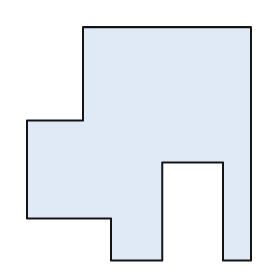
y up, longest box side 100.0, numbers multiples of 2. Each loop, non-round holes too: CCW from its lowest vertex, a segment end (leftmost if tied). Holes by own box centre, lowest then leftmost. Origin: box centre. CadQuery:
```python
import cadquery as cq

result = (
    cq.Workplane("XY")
    .moveTo(-12.0, -50.0)
    .lineTo(10.0, -50.0)
    .lineTo(10.0, -8.0)
    .lineTo(36.0, -8.0)
    .lineTo(36.0, -50.0)
    .lineTo(48.0, -50.0)
    .lineTo(48.0, 50.0)
    .lineTo(-24.0, 50.0)
    .lineTo(-24.0, 10.0)
    .lineTo(-48.0, 10.0)
    .lineTo(-48.0, -32.0)
    .lineTo(-12.0, -32.0)
    .close()
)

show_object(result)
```